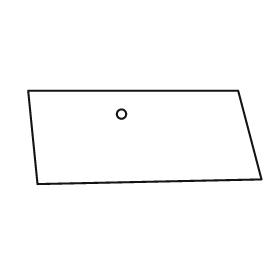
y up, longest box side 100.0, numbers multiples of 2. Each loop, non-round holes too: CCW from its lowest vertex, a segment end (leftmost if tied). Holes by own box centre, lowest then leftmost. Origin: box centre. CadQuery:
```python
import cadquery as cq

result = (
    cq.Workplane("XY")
    .moveTo(-46.0, -20.0)
    .lineTo(50.0, -18.0)
    .lineTo(40.0, 20.0)
    .lineTo(-50.0, 20.0)
    .close()
    .moveTo(-10.0, 10.0)
    .circle(2.0)
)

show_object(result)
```